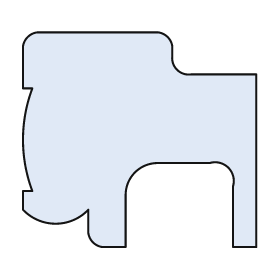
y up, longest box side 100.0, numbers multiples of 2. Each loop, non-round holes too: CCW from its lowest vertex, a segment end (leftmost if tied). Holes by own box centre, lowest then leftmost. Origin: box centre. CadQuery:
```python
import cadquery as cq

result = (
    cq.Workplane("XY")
    .moveTo(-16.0, -46.0)
    .lineTo(-6.0, -46.0)
    .lineTo(-6.0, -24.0)
    .threePointArc((-2.0, -14.0), (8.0, -10.0))
    .lineTo(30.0, -10.0)
    .threePointArc((38.0, -12.0), (40.0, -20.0))
    .lineTo(40.0, -46.0)
    .lineTo(50.0, -46.0)
    .lineTo(50.0, 28.0)
    .lineTo(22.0, 28.0)
    .threePointArc((16.0, 30.0), (14.0, 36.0))
    .lineTo(14.0, 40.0)
    .threePointArc((12.0, 44.0), (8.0, 46.0))
    .lineTo(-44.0, 46.0)
    .threePointArc((-48.0, 44.0), (-50.0, 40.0))
    .lineTo(-50.0, 22.0)
    .lineTo(-46.0, 22.0)
    .threePointArc((-50.0, 0.0), (-46.0, -22.0))
    .lineTo(-50.0, -22.0)
    .lineTo(-50.0, -30.0)
    .threePointArc((-36.0, -36.0), (-22.0, -30.0))
    .lineTo(-22.0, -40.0)
    .threePointArc((-20.0, -44.0), (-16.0, -46.0))
    .close()
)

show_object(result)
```